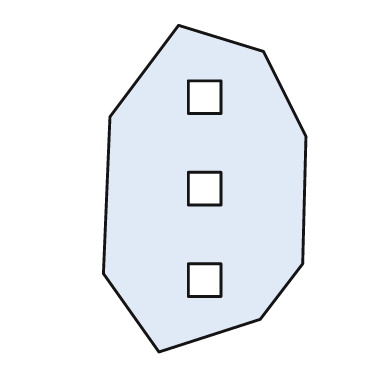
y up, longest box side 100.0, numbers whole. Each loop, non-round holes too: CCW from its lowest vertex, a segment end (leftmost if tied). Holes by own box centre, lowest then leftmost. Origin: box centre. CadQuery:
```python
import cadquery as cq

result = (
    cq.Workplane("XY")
    .moveTo(-14.0, -50.0)
    .lineTo(17.0, -40.0)
    .lineTo(30.0, -23.0)
    .lineTo(31.0, 16.0)
    .lineTo(18.0, 42.0)
    .lineTo(-8.0, 50.0)
    .lineTo(-29.0, 22.0)
    .lineTo(-31.0, -26.0)
    .close()
    .moveTo(-5.0, -33.0)
    .lineTo(5.0, -33.0)
    .lineTo(5.0, -23.0)
    .lineTo(-5.0, -23.0)
    .close()
    .moveTo(-5.0, -5.0)
    .lineTo(5.0, -5.0)
    .lineTo(5.0, 5.0)
    .lineTo(-5.0, 5.0)
    .close()
    .moveTo(-5.0, 23.0)
    .lineTo(5.0, 23.0)
    .lineTo(5.0, 33.0)
    .lineTo(-5.0, 33.0)
    .close()
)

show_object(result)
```